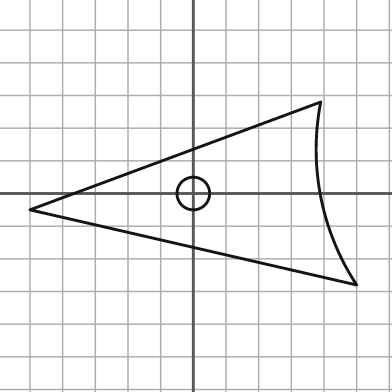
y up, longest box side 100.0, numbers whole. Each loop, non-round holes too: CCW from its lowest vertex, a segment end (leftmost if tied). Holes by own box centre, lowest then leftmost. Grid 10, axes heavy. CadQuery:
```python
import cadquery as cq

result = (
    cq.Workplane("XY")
    .moveTo(50.0, -28.0)
    .threePointArc((39.0, -1.0), (39.0, 28.0))
    .lineTo(-50.0, -5.0)
    .close()
    .moveTo(0.0, 0.0)
    .circle(5.0)
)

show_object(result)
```